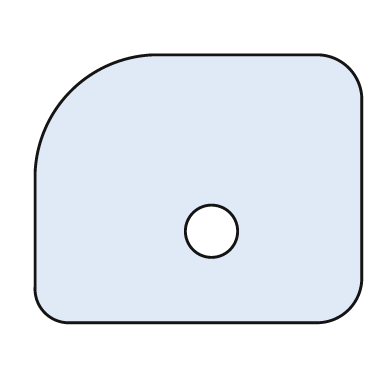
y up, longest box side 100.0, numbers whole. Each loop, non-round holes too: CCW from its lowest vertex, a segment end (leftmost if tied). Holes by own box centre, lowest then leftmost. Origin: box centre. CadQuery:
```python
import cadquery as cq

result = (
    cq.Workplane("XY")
    .moveTo(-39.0, -41.0)
    .lineTo(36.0, -41.0)
    .threePointArc((46.0, -37.0), (50.0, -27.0))
    .lineTo(50.0, 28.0)
    .threePointArc((46.0, 37.0), (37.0, 41.0))
    .lineTo(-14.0, 41.0)
    .threePointArc((-39.0, 30.0), (-50.0, 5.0))
    .lineTo(-50.0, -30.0)
    .threePointArc((-47.0, -38.0), (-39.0, -41.0))
    .close()
    .moveTo(4.0, -13.0)
    .circle(8.0)
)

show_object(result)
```